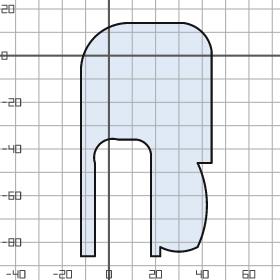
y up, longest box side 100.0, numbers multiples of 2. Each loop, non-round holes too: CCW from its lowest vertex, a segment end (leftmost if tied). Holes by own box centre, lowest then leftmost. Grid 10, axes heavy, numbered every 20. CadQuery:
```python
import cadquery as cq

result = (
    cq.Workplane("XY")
    .moveTo(-12.0, -86.0)
    .lineTo(-6.0, -86.0)
    .lineTo(-6.0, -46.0)
    .threePointArc((-4.0, -38.0), (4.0, -36.0))
    .lineTo(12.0, -36.0)
    .threePointArc((16.0, -38.0), (18.0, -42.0))
    .lineTo(18.0, -86.0)
    .lineTo(22.0, -86.0)
    .lineTo(22.0, -82.0)
    .threePointArc((30.0, -84.0), (38.0, -82.0))
    .threePointArc((42.0, -64.0), (38.0, -46.0))
    .lineTo(44.0, -46.0)
    .lineTo(44.0, 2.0)
    .threePointArc((40.0, 10.0), (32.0, 14.0))
    .lineTo(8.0, 14.0)
    .threePointArc((-6.0, 8.0), (-12.0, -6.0))
    .close()
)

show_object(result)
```